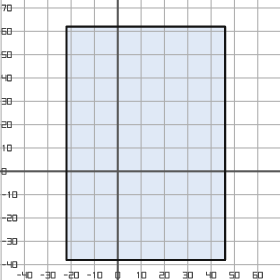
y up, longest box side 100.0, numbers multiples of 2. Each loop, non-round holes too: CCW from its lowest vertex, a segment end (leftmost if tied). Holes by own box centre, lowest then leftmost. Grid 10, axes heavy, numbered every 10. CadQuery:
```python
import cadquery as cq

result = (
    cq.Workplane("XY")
    .moveTo(-22.0, -38.0)
    .lineTo(46.0, -38.0)
    .lineTo(46.0, 62.0)
    .lineTo(-22.0, 62.0)
    .close()
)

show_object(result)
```